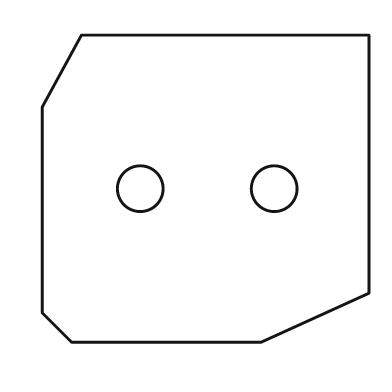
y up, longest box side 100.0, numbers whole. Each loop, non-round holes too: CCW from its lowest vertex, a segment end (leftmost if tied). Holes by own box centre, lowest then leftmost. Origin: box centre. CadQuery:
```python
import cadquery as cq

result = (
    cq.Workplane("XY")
    .moveTo(-41.0, -47.0)
    .lineTo(17.0, -47.0)
    .lineTo(50.0, -32.0)
    .lineTo(50.0, 47.0)
    .lineTo(-38.0, 47.0)
    .lineTo(-50.0, 25.0)
    .lineTo(-50.0, -38.0)
    .close()
    .moveTo(-20.0, 0.0)
    .circle(7.0)
    .moveTo(21.0, 0.0)
    .circle(7.0)
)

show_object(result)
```